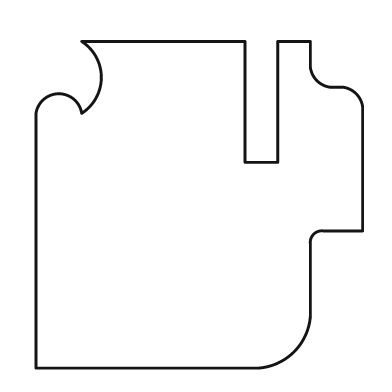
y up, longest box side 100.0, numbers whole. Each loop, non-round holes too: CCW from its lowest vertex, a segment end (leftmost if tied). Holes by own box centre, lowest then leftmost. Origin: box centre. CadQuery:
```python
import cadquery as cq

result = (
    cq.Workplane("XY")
    .moveTo(-50.0, -50.0)
    .lineTo(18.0, -50.0)
    .threePointArc((29.0, -45.0), (34.0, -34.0))
    .lineTo(34.0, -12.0)
    .threePointArc((35.0, -9.0), (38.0, -8.0))
    .lineTo(50.0, -8.0)
    .lineTo(50.0, 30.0)
    .threePointArc((48.0, 34.0), (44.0, 36.0))
    .lineTo(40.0, 36.0)
    .threePointArc((36.0, 38.0), (34.0, 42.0))
    .lineTo(34.0, 50.0)
    .lineTo(24.0, 50.0)
    .lineTo(24.0, 13.0)
    .lineTo(14.0, 13.0)
    .lineTo(14.0, 50.0)
    .lineTo(-36.0, 50.0)
    .threePointArc((-30.0, 39.0), (-36.0, 28.0))
    .threePointArc((-43.0, 34.0), (-50.0, 28.0))
    .close()
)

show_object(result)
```